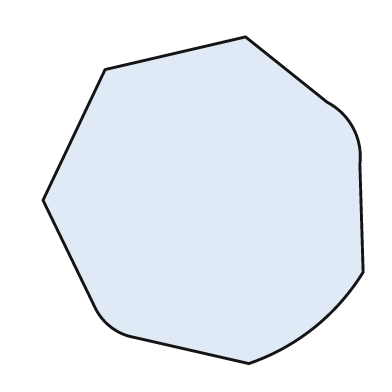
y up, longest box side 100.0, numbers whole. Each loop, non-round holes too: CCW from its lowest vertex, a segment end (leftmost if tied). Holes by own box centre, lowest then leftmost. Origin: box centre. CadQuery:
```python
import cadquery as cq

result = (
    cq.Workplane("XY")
    .moveTo(14.0, -50.0)
    .threePointArc((34.0, -39.0), (49.0, -22.0))
    .lineTo(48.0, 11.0)
    .threePointArc((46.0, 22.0), (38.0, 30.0))
    .lineTo(13.0, 50.0)
    .lineTo(-30.0, 40.0)
    .lineTo(-49.0, 0.0)
    .lineTo(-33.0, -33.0)
    .threePointArc((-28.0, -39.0), (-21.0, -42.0))
    .close()
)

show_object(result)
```